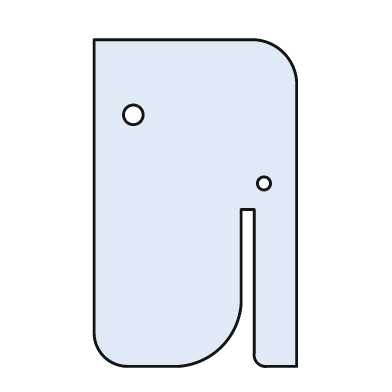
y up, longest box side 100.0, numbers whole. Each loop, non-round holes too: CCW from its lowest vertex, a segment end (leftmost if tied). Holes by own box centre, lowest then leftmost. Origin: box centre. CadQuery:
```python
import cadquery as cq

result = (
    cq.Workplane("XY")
    .moveTo(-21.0, -50.0)
    .lineTo(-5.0, -50.0)
    .threePointArc((8.0, -44.0), (14.0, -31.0))
    .lineTo(14.0, -2.0)
    .lineTo(18.0, -2.0)
    .lineTo(18.0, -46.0)
    .threePointArc((19.0, -49.0), (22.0, -50.0))
    .lineTo(31.0, -50.0)
    .lineTo(31.0, 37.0)
    .threePointArc((27.0, 46.0), (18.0, 50.0))
    .lineTo(-31.0, 50.0)
    .lineTo(-31.0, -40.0)
    .threePointArc((-28.0, -47.0), (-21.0, -50.0))
    .close()
    .moveTo(21.0, 6.0)
    .circle(2.0)
    .moveTo(-19.0, 27.0)
    .circle(3.0)
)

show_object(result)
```